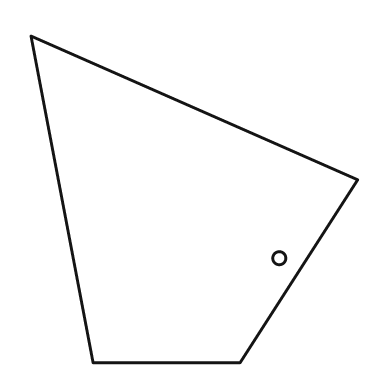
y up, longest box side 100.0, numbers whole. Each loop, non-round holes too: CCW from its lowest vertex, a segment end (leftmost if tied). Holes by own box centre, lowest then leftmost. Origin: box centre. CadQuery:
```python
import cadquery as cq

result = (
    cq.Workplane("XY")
    .moveTo(-31.0, -50.0)
    .lineTo(14.0, -50.0)
    .lineTo(50.0, 6.0)
    .lineTo(-50.0, 50.0)
    .close()
    .moveTo(26.0, -18.0)
    .circle(2.0)
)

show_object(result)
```